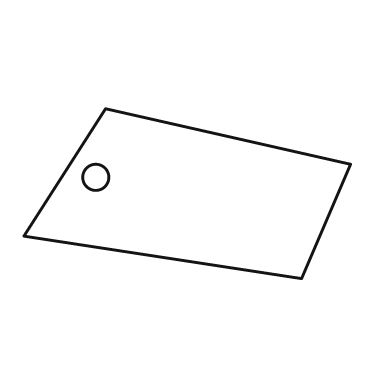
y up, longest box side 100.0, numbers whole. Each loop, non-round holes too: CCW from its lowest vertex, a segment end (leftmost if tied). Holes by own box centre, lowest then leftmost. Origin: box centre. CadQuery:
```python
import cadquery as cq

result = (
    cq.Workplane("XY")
    .moveTo(35.0, -26.0)
    .lineTo(50.0, 9.0)
    .lineTo(-25.0, 26.0)
    .lineTo(-50.0, -13.0)
    .close()
    .moveTo(-28.0, 5.0)
    .circle(4.0)
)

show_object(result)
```